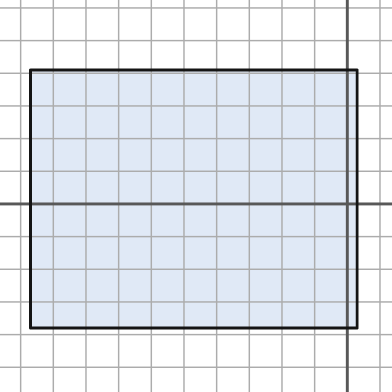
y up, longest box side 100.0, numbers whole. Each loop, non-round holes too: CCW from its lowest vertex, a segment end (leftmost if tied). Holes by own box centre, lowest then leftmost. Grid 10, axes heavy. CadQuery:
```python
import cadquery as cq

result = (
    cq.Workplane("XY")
    .moveTo(-97.0, -38.0)
    .lineTo(3.0, -38.0)
    .lineTo(3.0, 41.0)
    .lineTo(-97.0, 41.0)
    .close()
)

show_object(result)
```